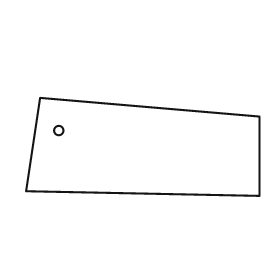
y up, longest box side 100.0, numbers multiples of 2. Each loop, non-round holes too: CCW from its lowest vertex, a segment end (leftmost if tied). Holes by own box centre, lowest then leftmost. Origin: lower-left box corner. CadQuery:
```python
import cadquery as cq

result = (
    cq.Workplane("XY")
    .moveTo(100.0, 0.0)
    .lineTo(100.0, 34.0)
    .lineTo(6.0, 42.0)
    .lineTo(0.0, 2.0)
    .close()
    .moveTo(14.0, 28.0)
    .circle(2.0)
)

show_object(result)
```